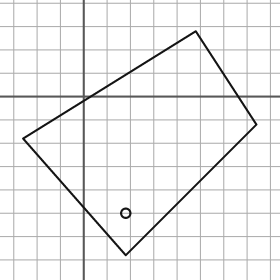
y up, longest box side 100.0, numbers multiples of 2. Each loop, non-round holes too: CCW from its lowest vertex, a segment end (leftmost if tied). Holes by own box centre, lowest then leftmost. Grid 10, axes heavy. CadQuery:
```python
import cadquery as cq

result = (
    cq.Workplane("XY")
    .moveTo(18.0, -68.0)
    .lineTo(74.0, -12.0)
    .lineTo(48.0, 28.0)
    .lineTo(-26.0, -18.0)
    .close()
    .moveTo(18.0, -50.0)
    .circle(2.0)
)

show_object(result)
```